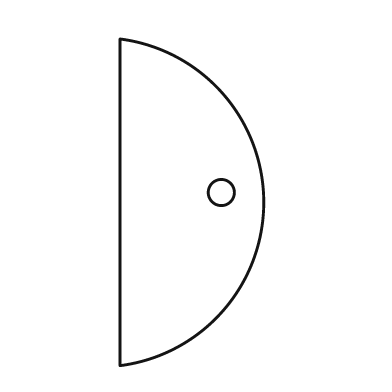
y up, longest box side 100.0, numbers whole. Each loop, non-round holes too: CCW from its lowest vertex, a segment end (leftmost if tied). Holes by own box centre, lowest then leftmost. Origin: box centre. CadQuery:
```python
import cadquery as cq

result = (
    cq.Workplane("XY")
    .moveTo(-22.0, -50.0)
    .threePointArc((22.0, 0.0), (-22.0, 50.0))
    .close()
    .moveTo(9.0, 3.0)
    .circle(4.0)
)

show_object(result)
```